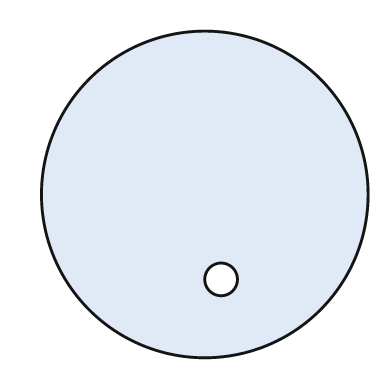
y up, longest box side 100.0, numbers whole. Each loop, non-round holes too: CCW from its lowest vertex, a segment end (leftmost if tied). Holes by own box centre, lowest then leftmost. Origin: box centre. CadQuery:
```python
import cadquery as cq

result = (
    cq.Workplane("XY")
    .moveTo(0.0, 0.0)
    .circle(50.0)
    .moveTo(5.0, -26.0)
    .circle(5.0)
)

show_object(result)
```